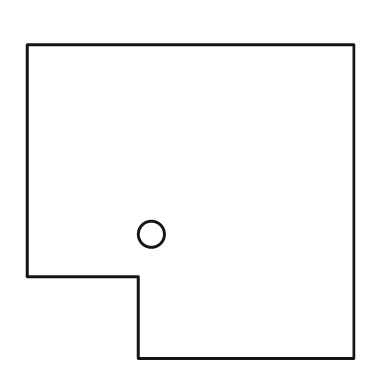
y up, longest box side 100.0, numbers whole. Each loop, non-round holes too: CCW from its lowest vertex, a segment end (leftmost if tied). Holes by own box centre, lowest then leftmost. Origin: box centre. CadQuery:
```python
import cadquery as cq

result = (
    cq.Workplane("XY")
    .moveTo(-16.0, -48.0)
    .lineTo(50.0, -48.0)
    .lineTo(50.0, 48.0)
    .lineTo(-50.0, 48.0)
    .lineTo(-50.0, -23.0)
    .lineTo(-16.0, -23.0)
    .close()
    .moveTo(-12.0, -10.0)
    .circle(4.0)
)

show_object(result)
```